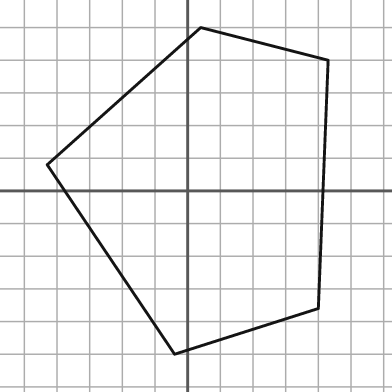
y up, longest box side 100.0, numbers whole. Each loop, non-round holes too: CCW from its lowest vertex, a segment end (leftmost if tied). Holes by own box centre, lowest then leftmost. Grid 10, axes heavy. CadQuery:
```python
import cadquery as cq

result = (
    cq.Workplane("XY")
    .moveTo(-4.0, -50.0)
    .lineTo(40.0, -36.0)
    .lineTo(43.0, 40.0)
    .lineTo(4.0, 50.0)
    .lineTo(-43.0, 8.0)
    .close()
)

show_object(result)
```